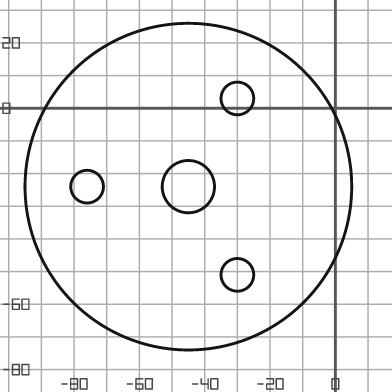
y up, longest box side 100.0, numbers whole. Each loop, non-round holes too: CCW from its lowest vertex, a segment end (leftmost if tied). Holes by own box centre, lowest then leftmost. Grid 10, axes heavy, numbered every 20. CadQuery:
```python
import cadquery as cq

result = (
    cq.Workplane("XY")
    .moveTo(-45.0, -24.0)
    .circle(50.0)
    .moveTo(-30.0, -51.0)
    .circle(5.0)
    .moveTo(-76.0, -24.0)
    .circle(5.0)
    .moveTo(-45.0, -24.0)
    .circle(8.0)
    .moveTo(-30.0, 3.0)
    .circle(5.0)
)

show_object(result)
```